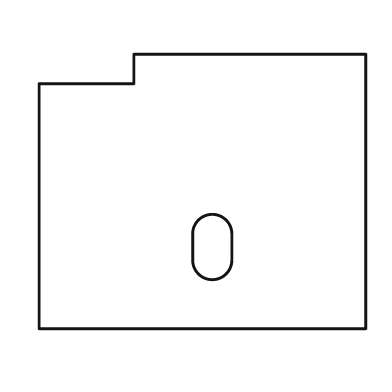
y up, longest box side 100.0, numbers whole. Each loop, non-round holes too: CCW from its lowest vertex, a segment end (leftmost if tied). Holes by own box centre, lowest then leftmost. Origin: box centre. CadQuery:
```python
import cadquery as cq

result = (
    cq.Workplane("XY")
    .moveTo(-50.0, -42.0)
    .lineTo(50.0, -42.0)
    .lineTo(50.0, 42.0)
    .lineTo(-21.0, 42.0)
    .lineTo(-21.0, 33.0)
    .lineTo(-50.0, 33.0)
    .close()
    .moveTo(-3.0, -21.0)
    .threePointArc((3.0, -27.0), (9.0, -21.0))
    .lineTo(9.0, -13.0)
    .threePointArc((3.0, -7.0), (-3.0, -13.0))
    .close()
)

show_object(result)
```